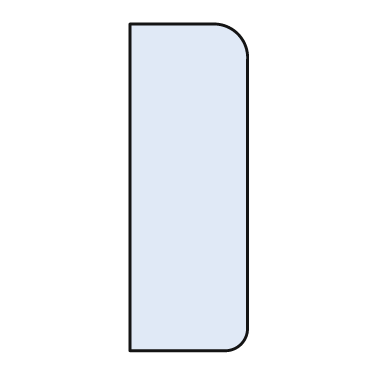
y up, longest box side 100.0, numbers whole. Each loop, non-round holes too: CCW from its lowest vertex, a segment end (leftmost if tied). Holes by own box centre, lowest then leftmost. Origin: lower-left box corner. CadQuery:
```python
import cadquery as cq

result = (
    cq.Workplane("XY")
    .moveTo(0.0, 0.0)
    .lineTo(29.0, 0.0)
    .threePointArc((34.0, 2.0), (36.0, 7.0))
    .lineTo(36.0, 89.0)
    .threePointArc((33.0, 97.0), (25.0, 100.0))
    .lineTo(0.0, 100.0)
    .close()
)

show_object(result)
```